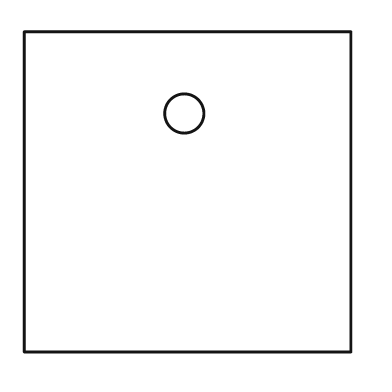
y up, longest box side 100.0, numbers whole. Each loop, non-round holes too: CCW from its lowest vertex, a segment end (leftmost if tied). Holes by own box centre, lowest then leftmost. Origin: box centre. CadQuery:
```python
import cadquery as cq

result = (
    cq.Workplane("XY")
    .moveTo(-50.0, -49.0)
    .lineTo(50.0, -49.0)
    .lineTo(50.0, 49.0)
    .lineTo(-50.0, 49.0)
    .close()
    .moveTo(-1.0, 24.0)
    .circle(6.0)
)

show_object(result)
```